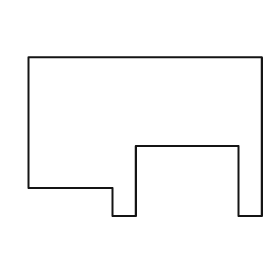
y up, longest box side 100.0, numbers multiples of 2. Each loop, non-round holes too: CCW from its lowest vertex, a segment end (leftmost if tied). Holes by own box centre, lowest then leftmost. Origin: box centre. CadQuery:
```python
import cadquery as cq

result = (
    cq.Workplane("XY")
    .moveTo(-14.0, -34.0)
    .lineTo(-4.0, -34.0)
    .lineTo(-4.0, -4.0)
    .lineTo(40.0, -4.0)
    .lineTo(40.0, -34.0)
    .lineTo(50.0, -34.0)
    .lineTo(50.0, 34.0)
    .lineTo(-50.0, 34.0)
    .lineTo(-50.0, -22.0)
    .lineTo(-14.0, -22.0)
    .close()
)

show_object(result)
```